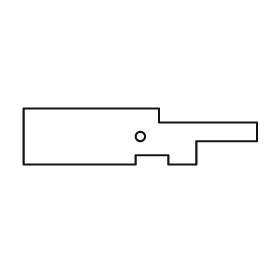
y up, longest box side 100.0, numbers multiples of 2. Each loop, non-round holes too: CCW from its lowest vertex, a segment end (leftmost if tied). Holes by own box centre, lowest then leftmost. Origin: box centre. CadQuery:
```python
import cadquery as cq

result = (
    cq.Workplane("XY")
    .moveTo(-50.0, -12.0)
    .lineTo(-2.0, -12.0)
    .lineTo(-2.0, -8.0)
    .lineTo(12.0, -8.0)
    .lineTo(12.0, -12.0)
    .lineTo(24.0, -12.0)
    .lineTo(24.0, -2.0)
    .lineTo(50.0, -2.0)
    .lineTo(50.0, 6.0)
    .lineTo(8.0, 6.0)
    .lineTo(8.0, 12.0)
    .lineTo(-50.0, 12.0)
    .close()
    .moveTo(0.0, 0.0)
    .circle(2.0)
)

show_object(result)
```